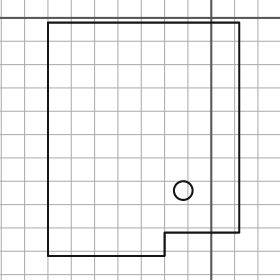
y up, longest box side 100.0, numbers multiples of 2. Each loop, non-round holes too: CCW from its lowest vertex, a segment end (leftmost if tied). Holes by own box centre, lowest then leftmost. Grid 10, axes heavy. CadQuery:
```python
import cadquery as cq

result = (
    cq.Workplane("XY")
    .moveTo(-70.0, -102.0)
    .lineTo(-20.0, -102.0)
    .lineTo(-20.0, -92.0)
    .lineTo(12.0, -92.0)
    .lineTo(12.0, -2.0)
    .lineTo(-70.0, -2.0)
    .close()
    .moveTo(-12.0, -74.0)
    .circle(4.0)
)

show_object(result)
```